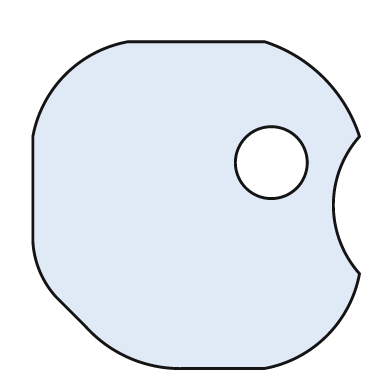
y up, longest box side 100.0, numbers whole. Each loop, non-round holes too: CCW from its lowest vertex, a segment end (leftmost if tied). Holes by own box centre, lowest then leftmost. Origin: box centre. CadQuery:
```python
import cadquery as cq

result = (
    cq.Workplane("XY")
    .moveTo(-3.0, -50.0)
    .lineTo(21.0, -50.0)
    .threePointArc((40.0, -40.0), (50.0, -21.0))
    .threePointArc((42.0, 0.0), (50.0, 21.0))
    .threePointArc((39.0, 39.0), (21.0, 50.0))
    .lineTo(-21.0, 50.0)
    .threePointArc((-40.0, 40.0), (-50.0, 21.0))
    .lineTo(-50.0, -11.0)
    .threePointArc((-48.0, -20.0), (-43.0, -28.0))
    .lineTo(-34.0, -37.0)
    .threePointArc((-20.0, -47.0), (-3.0, -50.0))
    .close()
    .moveTo(23.0, 13.0)
    .circle(11.0)
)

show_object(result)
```